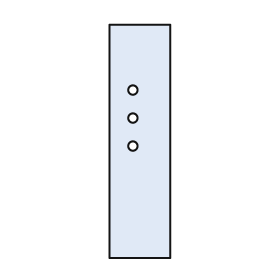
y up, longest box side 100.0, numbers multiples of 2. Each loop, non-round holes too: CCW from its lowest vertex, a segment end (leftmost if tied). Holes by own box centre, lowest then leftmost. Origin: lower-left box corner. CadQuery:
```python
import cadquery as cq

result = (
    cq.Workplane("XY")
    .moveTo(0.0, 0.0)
    .lineTo(26.0, 0.0)
    .lineTo(26.0, 100.0)
    .lineTo(0.0, 100.0)
    .close()
    .moveTo(10.0, 48.0)
    .circle(2.0)
    .moveTo(10.0, 60.0)
    .circle(2.0)
    .moveTo(10.0, 72.0)
    .circle(2.0)
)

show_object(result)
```